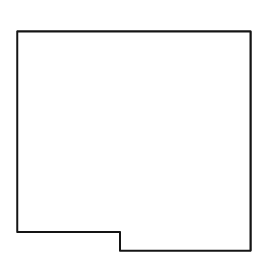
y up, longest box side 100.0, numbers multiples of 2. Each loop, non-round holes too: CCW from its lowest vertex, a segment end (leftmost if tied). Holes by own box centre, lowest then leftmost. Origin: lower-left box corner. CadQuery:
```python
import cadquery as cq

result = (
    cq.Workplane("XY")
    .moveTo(44.0, 0.0)
    .lineTo(100.0, 0.0)
    .lineTo(100.0, 94.0)
    .lineTo(0.0, 94.0)
    .lineTo(0.0, 8.0)
    .lineTo(44.0, 8.0)
    .close()
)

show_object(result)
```